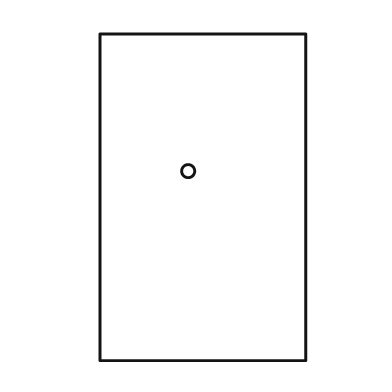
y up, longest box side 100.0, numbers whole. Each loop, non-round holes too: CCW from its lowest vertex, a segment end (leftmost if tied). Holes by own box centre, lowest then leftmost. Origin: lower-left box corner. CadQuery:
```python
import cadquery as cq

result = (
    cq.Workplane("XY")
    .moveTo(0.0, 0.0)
    .lineTo(63.0, 0.0)
    .lineTo(63.0, 100.0)
    .lineTo(0.0, 100.0)
    .close()
    .moveTo(27.0, 58.0)
    .circle(2.0)
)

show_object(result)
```